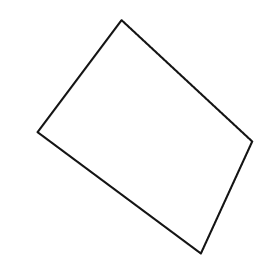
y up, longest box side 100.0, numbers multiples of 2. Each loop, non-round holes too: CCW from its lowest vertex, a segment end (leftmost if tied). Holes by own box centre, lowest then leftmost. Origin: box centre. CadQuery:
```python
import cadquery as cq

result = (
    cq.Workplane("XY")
    .moveTo(24.0, -50.0)
    .lineTo(46.0, -2.0)
    .lineTo(-10.0, 50.0)
    .lineTo(-46.0, 2.0)
    .close()
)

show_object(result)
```